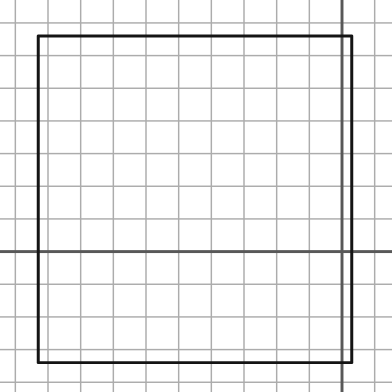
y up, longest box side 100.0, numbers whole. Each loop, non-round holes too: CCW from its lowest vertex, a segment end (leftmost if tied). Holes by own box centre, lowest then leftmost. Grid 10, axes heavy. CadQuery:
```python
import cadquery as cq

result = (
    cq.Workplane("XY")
    .moveTo(-93.0, -34.0)
    .lineTo(3.0, -34.0)
    .lineTo(3.0, 66.0)
    .lineTo(-93.0, 66.0)
    .close()
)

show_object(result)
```